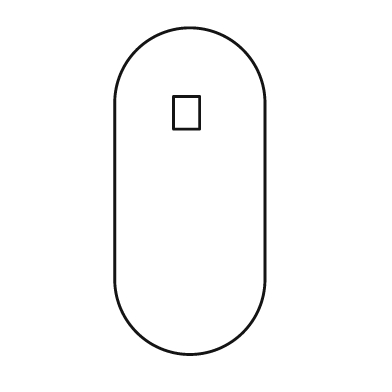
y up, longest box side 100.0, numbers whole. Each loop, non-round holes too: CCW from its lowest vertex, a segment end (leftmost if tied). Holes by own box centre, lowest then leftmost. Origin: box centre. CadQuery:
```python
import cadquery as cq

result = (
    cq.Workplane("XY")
    .moveTo(-23.0, -27.0)
    .threePointArc((0.0, -50.0), (23.0, -27.0))
    .lineTo(23.0, 27.0)
    .threePointArc((0.0, 50.0), (-23.0, 27.0))
    .close()
    .moveTo(-5.0, 19.0)
    .lineTo(3.0, 19.0)
    .lineTo(3.0, 29.0)
    .lineTo(-5.0, 29.0)
    .close()
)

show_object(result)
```